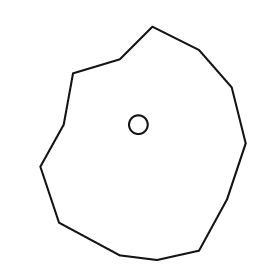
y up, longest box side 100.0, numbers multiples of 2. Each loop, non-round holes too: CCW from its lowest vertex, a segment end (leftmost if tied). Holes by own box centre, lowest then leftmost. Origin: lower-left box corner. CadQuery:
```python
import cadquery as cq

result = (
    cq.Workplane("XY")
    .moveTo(50.0, 0.0)
    .lineTo(68.0, 4.0)
    .lineTo(80.0, 26.0)
    .lineTo(88.0, 50.0)
    .lineTo(82.0, 74.0)
    .lineTo(68.0, 90.0)
    .lineTo(48.0, 100.0)
    .lineTo(34.0, 86.0)
    .lineTo(14.0, 80.0)
    .lineTo(10.0, 58.0)
    .lineTo(0.0, 40.0)
    .lineTo(8.0, 16.0)
    .lineTo(34.0, 2.0)
    .close()
    .moveTo(42.0, 58.0)
    .circle(4.0)
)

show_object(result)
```